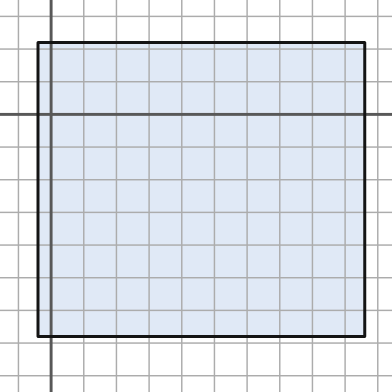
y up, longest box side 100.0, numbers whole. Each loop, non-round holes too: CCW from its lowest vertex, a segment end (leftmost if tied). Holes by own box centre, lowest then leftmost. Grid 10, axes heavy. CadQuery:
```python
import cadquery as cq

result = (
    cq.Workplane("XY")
    .moveTo(-4.0, -68.0)
    .lineTo(96.0, -68.0)
    .lineTo(96.0, 22.0)
    .lineTo(-4.0, 22.0)
    .close()
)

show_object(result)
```